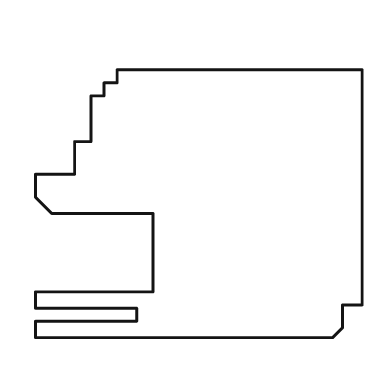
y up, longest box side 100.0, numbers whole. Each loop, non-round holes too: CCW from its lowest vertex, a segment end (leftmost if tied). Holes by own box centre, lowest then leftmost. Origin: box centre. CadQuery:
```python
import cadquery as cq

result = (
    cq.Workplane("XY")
    .moveTo(-50.0, -41.0)
    .lineTo(41.0, -41.0)
    .lineTo(44.0, -38.0)
    .lineTo(44.0, -31.0)
    .lineTo(50.0, -31.0)
    .lineTo(50.0, 41.0)
    .lineTo(-25.0, 41.0)
    .lineTo(-25.0, 37.0)
    .lineTo(-29.0, 37.0)
    .lineTo(-29.0, 33.0)
    .lineTo(-33.0, 33.0)
    .lineTo(-33.0, 19.0)
    .lineTo(-38.0, 19.0)
    .lineTo(-38.0, 9.0)
    .lineTo(-50.0, 9.0)
    .lineTo(-50.0, 2.0)
    .lineTo(-45.0, -3.0)
    .lineTo(-14.0, -3.0)
    .lineTo(-14.0, -27.0)
    .lineTo(-50.0, -27.0)
    .lineTo(-50.0, -32.0)
    .lineTo(-19.0, -32.0)
    .lineTo(-19.0, -36.0)
    .lineTo(-50.0, -36.0)
    .close()
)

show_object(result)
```